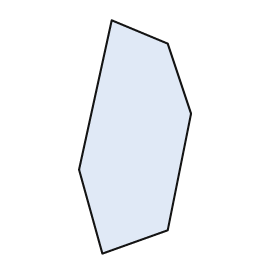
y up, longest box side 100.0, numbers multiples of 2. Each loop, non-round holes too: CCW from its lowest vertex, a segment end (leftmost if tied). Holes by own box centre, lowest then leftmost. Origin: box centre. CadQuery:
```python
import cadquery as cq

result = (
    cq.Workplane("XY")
    .moveTo(-14.0, -50.0)
    .lineTo(14.0, -40.0)
    .lineTo(24.0, 10.0)
    .lineTo(14.0, 40.0)
    .lineTo(-10.0, 50.0)
    .lineTo(-24.0, -14.0)
    .close()
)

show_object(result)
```